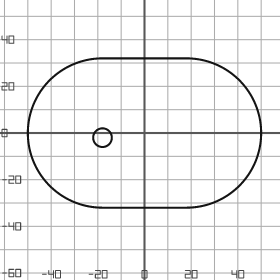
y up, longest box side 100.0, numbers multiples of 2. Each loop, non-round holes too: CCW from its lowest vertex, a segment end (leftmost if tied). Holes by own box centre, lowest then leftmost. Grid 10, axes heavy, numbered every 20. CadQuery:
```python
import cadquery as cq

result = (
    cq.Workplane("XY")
    .moveTo(-18.0, -32.0)
    .lineTo(18.0, -32.0)
    .threePointArc((50.0, 0.0), (18.0, 32.0))
    .lineTo(-18.0, 32.0)
    .threePointArc((-50.0, 0.0), (-18.0, -32.0))
    .close()
    .moveTo(-18.0, -2.0)
    .circle(4.0)
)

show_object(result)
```